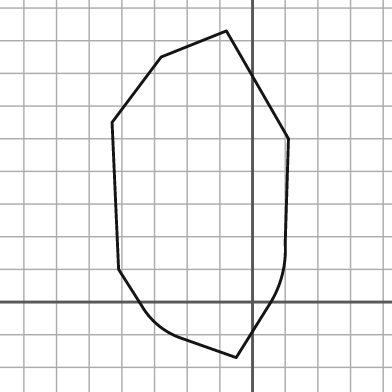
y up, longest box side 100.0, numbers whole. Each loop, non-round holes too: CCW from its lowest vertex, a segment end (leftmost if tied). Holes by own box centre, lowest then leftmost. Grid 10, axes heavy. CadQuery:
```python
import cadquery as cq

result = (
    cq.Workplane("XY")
    .moveTo(-5.0, -17.0)
    .lineTo(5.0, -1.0)
    .threePointArc((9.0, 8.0), (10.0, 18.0))
    .lineTo(11.0, 50.0)
    .lineTo(-8.0, 83.0)
    .lineTo(-28.0, 75.0)
    .lineTo(-43.0, 55.0)
    .lineTo(-41.0, 10.0)
    .lineTo(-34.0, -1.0)
    .threePointArc((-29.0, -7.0), (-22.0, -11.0))
    .close()
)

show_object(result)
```